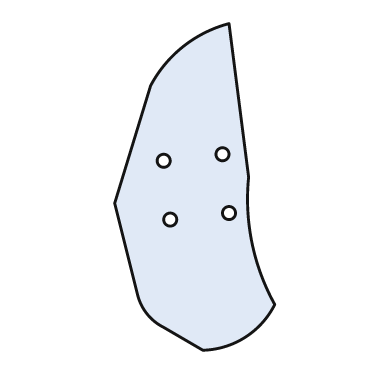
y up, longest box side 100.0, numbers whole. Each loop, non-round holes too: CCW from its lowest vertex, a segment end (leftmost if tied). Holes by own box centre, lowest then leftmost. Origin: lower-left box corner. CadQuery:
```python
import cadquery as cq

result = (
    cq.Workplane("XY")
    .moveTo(27.0, 0.0)
    .threePointArc((40.0, 4.0), (49.0, 14.0))
    .threePointArc((42.0, 33.0), (41.0, 53.0))
    .lineTo(35.0, 100.0)
    .threePointArc((21.0, 93.0), (11.0, 81.0))
    .lineTo(0.0, 45.0)
    .lineTo(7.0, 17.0)
    .threePointArc((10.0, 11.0), (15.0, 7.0))
    .close()
    .moveTo(17.0, 40.0)
    .circle(2.0)
    .moveTo(35.0, 42.0)
    .circle(2.0)
    .moveTo(15.0, 58.0)
    .circle(2.0)
    .moveTo(33.0, 60.0)
    .circle(2.0)
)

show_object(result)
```